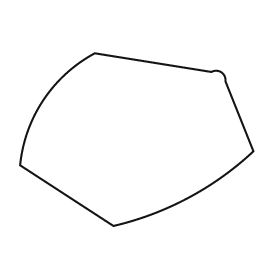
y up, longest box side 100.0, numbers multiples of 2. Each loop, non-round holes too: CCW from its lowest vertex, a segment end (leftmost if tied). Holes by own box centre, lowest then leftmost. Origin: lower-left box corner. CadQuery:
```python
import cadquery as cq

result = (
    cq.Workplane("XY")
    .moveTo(40.0, 0.0)
    .threePointArc((72.0, 12.0), (100.0, 32.0))
    .lineTo(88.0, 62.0)
    .threePointArc((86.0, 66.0), (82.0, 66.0))
    .lineTo(32.0, 74.0)
    .threePointArc((10.0, 54.0), (0.0, 26.0))
    .close()
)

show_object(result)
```